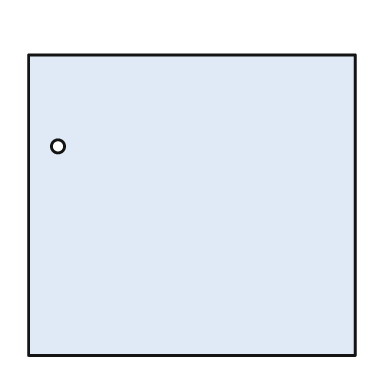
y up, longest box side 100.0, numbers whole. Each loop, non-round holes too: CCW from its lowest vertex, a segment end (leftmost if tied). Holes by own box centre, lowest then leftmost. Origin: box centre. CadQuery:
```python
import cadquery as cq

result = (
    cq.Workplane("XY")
    .moveTo(-50.0, -46.0)
    .lineTo(50.0, -46.0)
    .lineTo(50.0, 46.0)
    .lineTo(-50.0, 46.0)
    .close()
    .moveTo(-41.0, 18.0)
    .circle(2.0)
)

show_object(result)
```